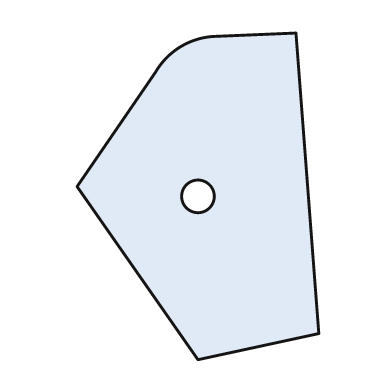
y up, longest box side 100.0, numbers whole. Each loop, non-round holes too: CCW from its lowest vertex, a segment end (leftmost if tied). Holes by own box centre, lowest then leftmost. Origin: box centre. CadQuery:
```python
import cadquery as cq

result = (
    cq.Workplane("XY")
    .moveTo(0.0, -50.0)
    .lineTo(37.0, -42.0)
    .lineTo(30.0, 50.0)
    .lineTo(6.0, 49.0)
    .threePointArc((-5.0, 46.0), (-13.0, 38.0))
    .lineTo(-37.0, 3.0)
    .close()
    .moveTo(0.0, 0.0)
    .circle(5.0)
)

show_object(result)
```